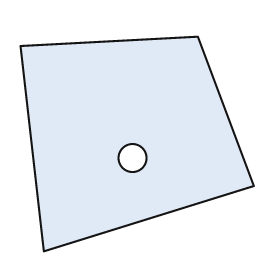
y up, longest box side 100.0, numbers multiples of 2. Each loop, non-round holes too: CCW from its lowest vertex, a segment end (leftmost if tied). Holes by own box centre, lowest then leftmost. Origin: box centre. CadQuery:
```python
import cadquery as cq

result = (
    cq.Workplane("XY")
    .moveTo(-40.0, -46.0)
    .lineTo(50.0, -18.0)
    .lineTo(26.0, 46.0)
    .lineTo(-50.0, 42.0)
    .close()
    .moveTo(-2.0, -6.0)
    .circle(6.0)
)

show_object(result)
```